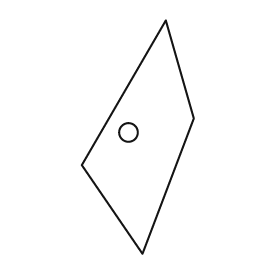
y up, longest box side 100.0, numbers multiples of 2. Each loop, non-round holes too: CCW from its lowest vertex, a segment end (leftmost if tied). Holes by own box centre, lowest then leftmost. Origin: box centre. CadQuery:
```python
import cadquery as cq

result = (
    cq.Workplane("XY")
    .moveTo(2.0, -50.0)
    .lineTo(24.0, 8.0)
    .lineTo(12.0, 50.0)
    .lineTo(-24.0, -12.0)
    .close()
    .moveTo(-4.0, 2.0)
    .circle(4.0)
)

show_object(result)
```